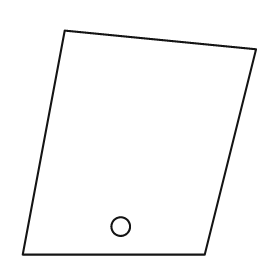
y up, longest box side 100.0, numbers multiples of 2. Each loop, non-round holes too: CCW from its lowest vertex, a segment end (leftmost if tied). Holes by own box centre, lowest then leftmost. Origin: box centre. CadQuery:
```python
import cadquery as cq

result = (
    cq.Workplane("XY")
    .moveTo(-50.0, -48.0)
    .lineTo(28.0, -48.0)
    .lineTo(50.0, 40.0)
    .lineTo(-32.0, 48.0)
    .close()
    .moveTo(-8.0, -36.0)
    .circle(4.0)
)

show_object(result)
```